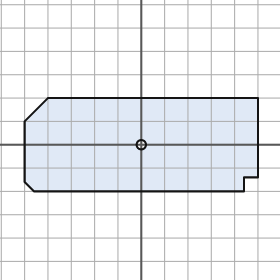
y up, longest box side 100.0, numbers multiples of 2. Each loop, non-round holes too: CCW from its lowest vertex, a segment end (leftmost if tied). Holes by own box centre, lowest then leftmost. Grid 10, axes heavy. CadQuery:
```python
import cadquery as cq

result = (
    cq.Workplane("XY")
    .moveTo(-46.0, -20.0)
    .lineTo(44.0, -20.0)
    .lineTo(44.0, -14.0)
    .lineTo(50.0, -14.0)
    .lineTo(50.0, 20.0)
    .lineTo(-40.0, 20.0)
    .lineTo(-50.0, 10.0)
    .lineTo(-50.0, -16.0)
    .close()
    .moveTo(0.0, 0.0)
    .circle(2.0)
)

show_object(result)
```